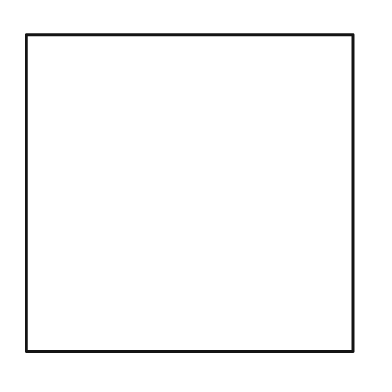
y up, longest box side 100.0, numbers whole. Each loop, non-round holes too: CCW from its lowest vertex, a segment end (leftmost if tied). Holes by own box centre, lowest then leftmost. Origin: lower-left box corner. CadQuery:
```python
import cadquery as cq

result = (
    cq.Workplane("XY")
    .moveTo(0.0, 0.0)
    .lineTo(100.0, 0.0)
    .lineTo(100.0, 97.0)
    .lineTo(0.0, 97.0)
    .close()
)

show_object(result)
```